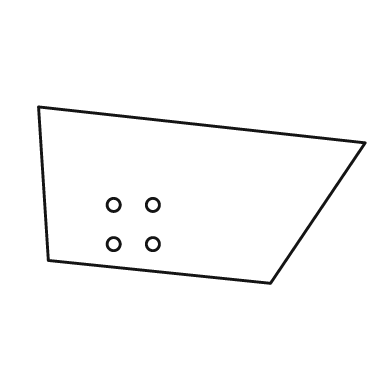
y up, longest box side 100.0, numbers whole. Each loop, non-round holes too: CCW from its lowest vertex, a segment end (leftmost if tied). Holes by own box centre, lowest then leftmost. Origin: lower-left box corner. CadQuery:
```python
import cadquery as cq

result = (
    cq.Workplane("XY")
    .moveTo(71.0, 0.0)
    .lineTo(100.0, 43.0)
    .lineTo(0.0, 54.0)
    .lineTo(3.0, 7.0)
    .close()
    .moveTo(23.0, 12.0)
    .circle(2.0)
    .moveTo(35.0, 12.0)
    .circle(2.0)
    .moveTo(23.0, 24.0)
    .circle(2.0)
    .moveTo(35.0, 24.0)
    .circle(2.0)
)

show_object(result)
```